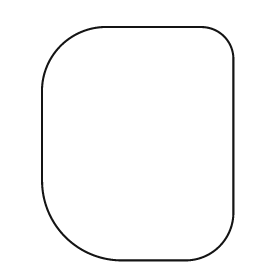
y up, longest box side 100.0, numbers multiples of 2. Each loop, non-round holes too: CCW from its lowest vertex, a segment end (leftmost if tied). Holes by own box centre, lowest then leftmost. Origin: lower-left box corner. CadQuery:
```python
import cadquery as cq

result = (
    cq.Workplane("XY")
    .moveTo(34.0, 0.0)
    .lineTo(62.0, 0.0)
    .threePointArc((76.0, 6.0), (82.0, 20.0))
    .lineTo(82.0, 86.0)
    .threePointArc((78.0, 96.0), (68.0, 100.0))
    .lineTo(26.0, 100.0)
    .threePointArc((8.0, 92.0), (0.0, 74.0))
    .lineTo(0.0, 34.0)
    .threePointArc((10.0, 10.0), (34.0, 0.0))
    .close()
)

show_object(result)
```